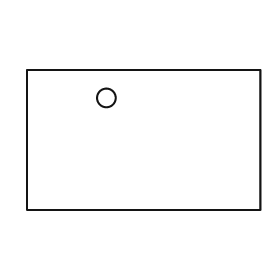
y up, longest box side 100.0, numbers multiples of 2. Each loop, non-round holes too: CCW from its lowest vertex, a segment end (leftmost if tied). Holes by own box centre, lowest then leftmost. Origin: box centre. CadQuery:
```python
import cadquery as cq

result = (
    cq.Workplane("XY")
    .moveTo(-50.0, -30.0)
    .lineTo(50.0, -30.0)
    .lineTo(50.0, 30.0)
    .lineTo(-50.0, 30.0)
    .close()
    .moveTo(-16.0, 18.0)
    .circle(4.0)
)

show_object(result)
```